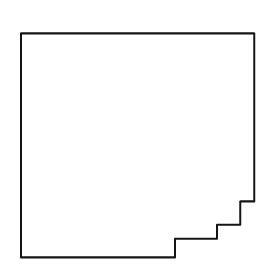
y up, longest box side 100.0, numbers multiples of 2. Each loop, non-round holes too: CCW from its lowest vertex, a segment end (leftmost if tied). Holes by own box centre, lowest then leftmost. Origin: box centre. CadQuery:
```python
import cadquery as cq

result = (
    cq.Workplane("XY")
    .moveTo(-50.0, -48.0)
    .lineTo(16.0, -48.0)
    .lineTo(16.0, -40.0)
    .lineTo(34.0, -40.0)
    .lineTo(34.0, -34.0)
    .lineTo(44.0, -34.0)
    .lineTo(44.0, -24.0)
    .lineTo(50.0, -24.0)
    .lineTo(50.0, 48.0)
    .lineTo(-50.0, 48.0)
    .close()
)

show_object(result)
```